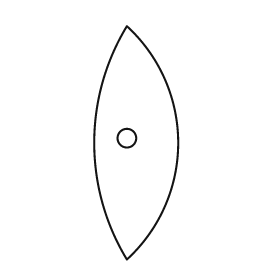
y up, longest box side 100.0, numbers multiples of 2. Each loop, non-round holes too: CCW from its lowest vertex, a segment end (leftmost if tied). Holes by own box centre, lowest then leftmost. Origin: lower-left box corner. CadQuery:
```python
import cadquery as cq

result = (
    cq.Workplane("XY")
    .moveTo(14.0, 0.0)
    .threePointArc((36.0, 50.0), (14.0, 100.0))
    .threePointArc((0.0, 50.0), (14.0, 0.0))
    .close()
    .moveTo(14.0, 52.0)
    .circle(4.0)
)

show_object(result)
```